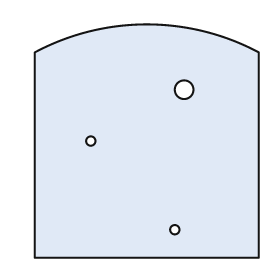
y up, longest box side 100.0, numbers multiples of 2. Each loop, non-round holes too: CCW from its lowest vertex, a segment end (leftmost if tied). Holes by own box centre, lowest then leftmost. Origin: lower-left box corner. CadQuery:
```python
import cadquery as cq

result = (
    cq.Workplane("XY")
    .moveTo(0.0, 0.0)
    .lineTo(96.0, 0.0)
    .lineTo(96.0, 88.0)
    .threePointArc((48.0, 100.0), (0.0, 88.0))
    .close()
    .moveTo(60.0, 12.0)
    .circle(2.0)
    .moveTo(24.0, 50.0)
    .circle(2.0)
    .moveTo(64.0, 72.0)
    .circle(4.0)
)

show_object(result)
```